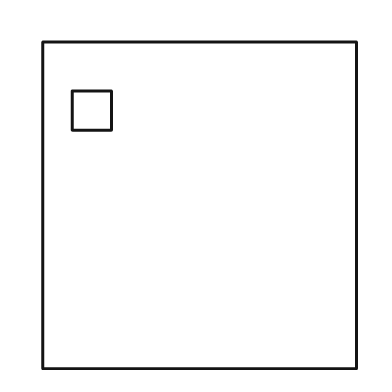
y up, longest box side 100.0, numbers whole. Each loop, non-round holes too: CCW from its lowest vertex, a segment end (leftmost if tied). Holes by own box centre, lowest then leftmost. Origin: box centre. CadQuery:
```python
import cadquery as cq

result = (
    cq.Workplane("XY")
    .moveTo(-48.0, -50.0)
    .lineTo(48.0, -50.0)
    .lineTo(48.0, 50.0)
    .lineTo(-48.0, 50.0)
    .close()
    .moveTo(-39.0, 23.0)
    .lineTo(-27.0, 23.0)
    .lineTo(-27.0, 35.0)
    .lineTo(-39.0, 35.0)
    .close()
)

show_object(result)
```